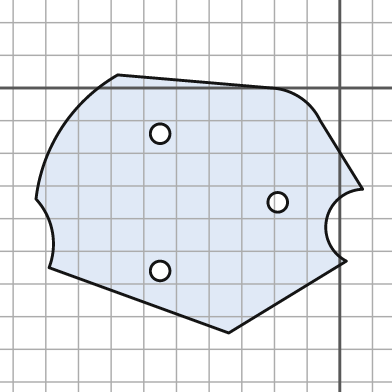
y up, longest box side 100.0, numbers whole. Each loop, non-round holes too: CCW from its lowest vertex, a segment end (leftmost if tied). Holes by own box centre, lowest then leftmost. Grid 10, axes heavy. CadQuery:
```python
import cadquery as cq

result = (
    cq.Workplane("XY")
    .moveTo(-34.0, -75.0)
    .lineTo(2.0, -53.0)
    .threePointArc((-4.0, -40.0), (7.0, -31.0))
    .lineTo(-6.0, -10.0)
    .threePointArc((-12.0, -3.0), (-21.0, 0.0))
    .lineTo(-68.0, 4.0)
    .threePointArc((-85.0, -12.0), (-93.0, -34.0))
    .threePointArc((-88.0, -44.0), (-89.0, -55.0))
    .close()
    .moveTo(-55.0, -56.0)
    .circle(3.0)
    .moveTo(-19.0, -35.0)
    .circle(3.0)
    .moveTo(-55.0, -14.0)
    .circle(3.0)
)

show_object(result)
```